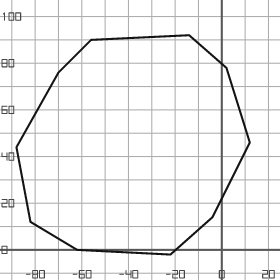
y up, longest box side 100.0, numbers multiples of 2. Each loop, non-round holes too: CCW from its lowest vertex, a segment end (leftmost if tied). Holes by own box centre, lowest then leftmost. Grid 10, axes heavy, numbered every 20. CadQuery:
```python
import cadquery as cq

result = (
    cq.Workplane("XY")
    .moveTo(-22.0, -2.0)
    .lineTo(-4.0, 14.0)
    .lineTo(12.0, 46.0)
    .lineTo(2.0, 78.0)
    .lineTo(-14.0, 92.0)
    .lineTo(-56.0, 90.0)
    .lineTo(-70.0, 76.0)
    .lineTo(-88.0, 44.0)
    .lineTo(-82.0, 12.0)
    .lineTo(-62.0, 0.0)
    .close()
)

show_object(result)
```